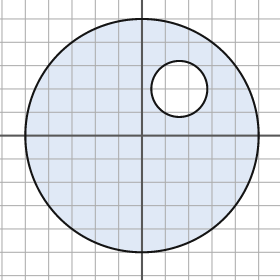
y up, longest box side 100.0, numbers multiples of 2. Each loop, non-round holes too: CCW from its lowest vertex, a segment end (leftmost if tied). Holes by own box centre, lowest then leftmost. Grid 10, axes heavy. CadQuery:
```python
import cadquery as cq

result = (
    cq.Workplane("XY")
    .moveTo(0.0, 0.0)
    .circle(50.0)
    .moveTo(16.0, 20.0)
    .circle(12.0)
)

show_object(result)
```